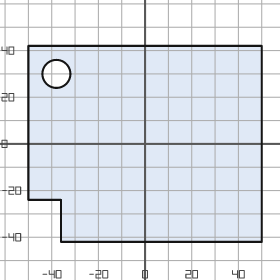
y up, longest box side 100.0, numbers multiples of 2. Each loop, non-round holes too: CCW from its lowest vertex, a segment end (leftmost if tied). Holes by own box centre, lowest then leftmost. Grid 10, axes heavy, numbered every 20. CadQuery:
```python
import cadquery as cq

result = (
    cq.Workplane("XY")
    .moveTo(-36.0, -42.0)
    .lineTo(50.0, -42.0)
    .lineTo(50.0, 42.0)
    .lineTo(-50.0, 42.0)
    .lineTo(-50.0, -24.0)
    .lineTo(-36.0, -24.0)
    .close()
    .moveTo(-38.0, 30.0)
    .circle(6.0)
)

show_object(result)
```